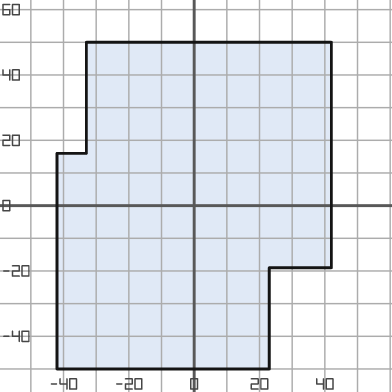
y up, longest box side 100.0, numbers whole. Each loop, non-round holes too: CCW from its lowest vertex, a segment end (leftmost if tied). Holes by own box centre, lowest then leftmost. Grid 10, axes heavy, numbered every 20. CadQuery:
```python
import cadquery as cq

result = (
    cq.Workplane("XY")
    .moveTo(-42.0, -50.0)
    .lineTo(23.0, -50.0)
    .lineTo(23.0, -19.0)
    .lineTo(42.0, -19.0)
    .lineTo(42.0, 50.0)
    .lineTo(-33.0, 50.0)
    .lineTo(-33.0, 16.0)
    .lineTo(-42.0, 16.0)
    .close()
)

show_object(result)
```